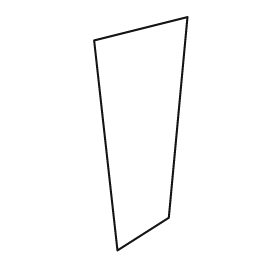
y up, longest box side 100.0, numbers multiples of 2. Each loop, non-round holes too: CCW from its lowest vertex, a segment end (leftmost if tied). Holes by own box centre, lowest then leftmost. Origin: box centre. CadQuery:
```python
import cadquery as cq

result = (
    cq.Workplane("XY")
    .moveTo(-10.0, -50.0)
    .lineTo(12.0, -36.0)
    .lineTo(20.0, 50.0)
    .lineTo(-20.0, 40.0)
    .close()
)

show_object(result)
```